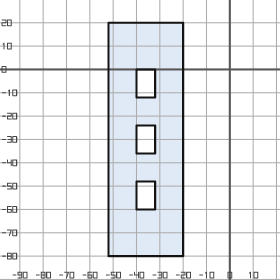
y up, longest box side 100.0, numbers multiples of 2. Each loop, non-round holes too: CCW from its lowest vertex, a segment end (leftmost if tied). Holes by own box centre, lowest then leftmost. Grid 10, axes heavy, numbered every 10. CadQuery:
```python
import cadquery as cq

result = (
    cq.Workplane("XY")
    .moveTo(-52.0, -80.0)
    .lineTo(-20.0, -80.0)
    .lineTo(-20.0, 20.0)
    .lineTo(-52.0, 20.0)
    .close()
    .moveTo(-40.0, -60.0)
    .lineTo(-32.0, -60.0)
    .lineTo(-32.0, -48.0)
    .lineTo(-40.0, -48.0)
    .close()
    .moveTo(-40.0, -36.0)
    .lineTo(-32.0, -36.0)
    .lineTo(-32.0, -24.0)
    .lineTo(-40.0, -24.0)
    .close()
    .moveTo(-40.0, -12.0)
    .lineTo(-32.0, -12.0)
    .lineTo(-32.0, 0.0)
    .lineTo(-40.0, 0.0)
    .close()
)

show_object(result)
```